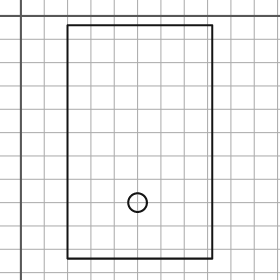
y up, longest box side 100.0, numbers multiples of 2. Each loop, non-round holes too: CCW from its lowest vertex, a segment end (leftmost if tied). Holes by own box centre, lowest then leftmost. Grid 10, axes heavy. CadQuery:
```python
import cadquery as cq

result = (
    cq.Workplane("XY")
    .moveTo(20.0, -104.0)
    .lineTo(82.0, -104.0)
    .lineTo(82.0, -4.0)
    .lineTo(20.0, -4.0)
    .close()
    .moveTo(50.0, -80.0)
    .circle(4.0)
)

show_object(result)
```